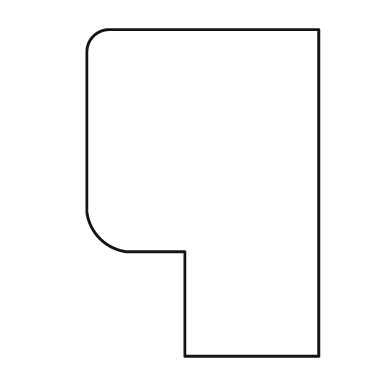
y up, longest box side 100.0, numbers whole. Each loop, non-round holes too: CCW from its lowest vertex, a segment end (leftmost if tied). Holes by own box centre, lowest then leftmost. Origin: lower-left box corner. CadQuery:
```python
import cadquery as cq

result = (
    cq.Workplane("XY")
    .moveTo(30.0, 0.0)
    .lineTo(71.0, 0.0)
    .lineTo(71.0, 100.0)
    .lineTo(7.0, 100.0)
    .threePointArc((2.0, 98.0), (0.0, 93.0))
    .lineTo(0.0, 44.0)
    .threePointArc((4.0, 36.0), (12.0, 32.0))
    .lineTo(30.0, 32.0)
    .close()
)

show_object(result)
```